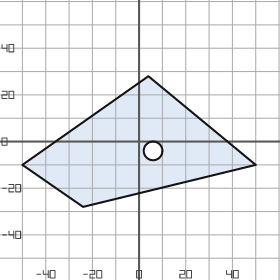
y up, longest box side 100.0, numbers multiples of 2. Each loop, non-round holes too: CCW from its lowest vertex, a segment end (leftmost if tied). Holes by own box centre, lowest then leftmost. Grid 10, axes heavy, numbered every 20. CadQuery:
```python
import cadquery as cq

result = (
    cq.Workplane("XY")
    .moveTo(-24.0, -28.0)
    .lineTo(50.0, -10.0)
    .lineTo(4.0, 28.0)
    .lineTo(-50.0, -10.0)
    .close()
    .moveTo(6.0, -4.0)
    .circle(4.0)
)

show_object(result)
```